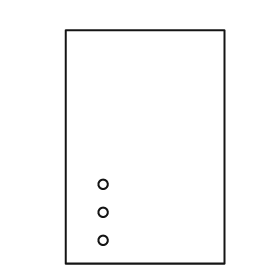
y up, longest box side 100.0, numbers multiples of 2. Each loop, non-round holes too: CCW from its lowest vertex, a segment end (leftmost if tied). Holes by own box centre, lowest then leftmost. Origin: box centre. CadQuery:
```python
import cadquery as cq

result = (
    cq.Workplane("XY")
    .moveTo(-34.0, -50.0)
    .lineTo(34.0, -50.0)
    .lineTo(34.0, 50.0)
    .lineTo(-34.0, 50.0)
    .close()
    .moveTo(-18.0, -40.0)
    .circle(2.0)
    .moveTo(-18.0, -28.0)
    .circle(2.0)
    .moveTo(-18.0, -16.0)
    .circle(2.0)
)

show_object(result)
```